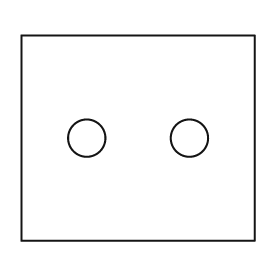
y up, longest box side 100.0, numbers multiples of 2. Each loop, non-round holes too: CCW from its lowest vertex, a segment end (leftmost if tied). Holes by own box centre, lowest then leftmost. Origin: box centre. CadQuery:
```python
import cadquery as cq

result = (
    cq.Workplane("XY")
    .moveTo(-50.0, -44.0)
    .lineTo(50.0, -44.0)
    .lineTo(50.0, 44.0)
    .lineTo(-50.0, 44.0)
    .close()
    .moveTo(-22.0, 0.0)
    .circle(8.0)
    .moveTo(22.0, 0.0)
    .circle(8.0)
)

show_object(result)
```